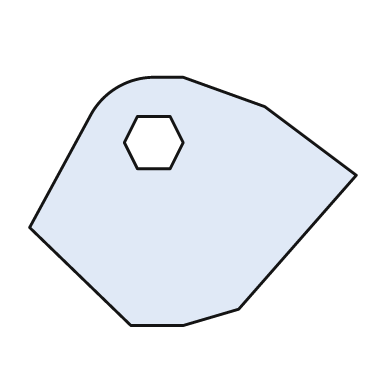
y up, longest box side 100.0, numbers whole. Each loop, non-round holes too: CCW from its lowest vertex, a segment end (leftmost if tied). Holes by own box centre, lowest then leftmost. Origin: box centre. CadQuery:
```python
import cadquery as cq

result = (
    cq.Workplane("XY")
    .moveTo(-19.0, -38.0)
    .lineTo(-3.0, -38.0)
    .lineTo(14.0, -33.0)
    .lineTo(50.0, 8.0)
    .lineTo(22.0, 29.0)
    .lineTo(-3.0, 38.0)
    .lineTo(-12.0, 38.0)
    .threePointArc((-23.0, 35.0), (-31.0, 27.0))
    .lineTo(-50.0, -8.0)
    .close()
    .moveTo(-17.0, 10.0)
    .lineTo(-7.0, 10.0)
    .lineTo(-3.0, 18.0)
    .lineTo(-7.0, 26.0)
    .lineTo(-17.0, 26.0)
    .lineTo(-21.0, 18.0)
    .close()
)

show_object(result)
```